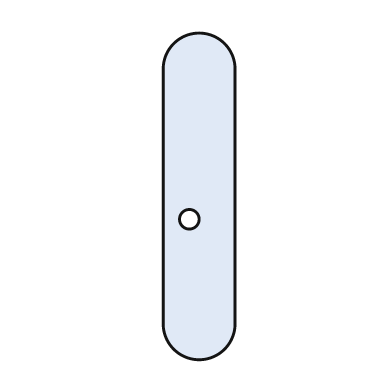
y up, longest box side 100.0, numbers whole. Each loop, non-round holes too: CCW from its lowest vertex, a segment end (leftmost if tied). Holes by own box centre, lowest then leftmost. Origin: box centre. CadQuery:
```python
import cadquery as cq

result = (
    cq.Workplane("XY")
    .moveTo(-11.0, -39.0)
    .threePointArc((0.0, -50.0), (11.0, -39.0))
    .lineTo(11.0, 39.0)
    .threePointArc((0.0, 50.0), (-11.0, 39.0))
    .close()
    .moveTo(-3.0, -7.0)
    .circle(3.0)
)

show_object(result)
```